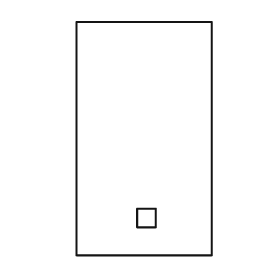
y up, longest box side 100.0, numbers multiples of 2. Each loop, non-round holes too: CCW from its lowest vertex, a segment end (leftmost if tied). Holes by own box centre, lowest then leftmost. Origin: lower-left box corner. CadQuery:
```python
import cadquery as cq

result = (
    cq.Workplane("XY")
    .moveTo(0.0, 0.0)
    .lineTo(58.0, 0.0)
    .lineTo(58.0, 100.0)
    .lineTo(0.0, 100.0)
    .close()
    .moveTo(26.0, 12.0)
    .lineTo(34.0, 12.0)
    .lineTo(34.0, 20.0)
    .lineTo(26.0, 20.0)
    .close()
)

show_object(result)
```